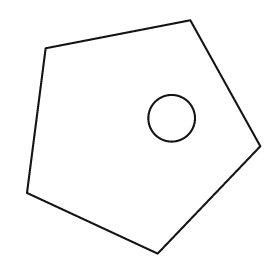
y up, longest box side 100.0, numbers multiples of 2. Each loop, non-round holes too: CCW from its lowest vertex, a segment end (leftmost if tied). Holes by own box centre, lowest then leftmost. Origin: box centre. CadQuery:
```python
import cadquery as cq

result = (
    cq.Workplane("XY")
    .moveTo(6.0, -50.0)
    .lineTo(50.0, -4.0)
    .lineTo(20.0, 50.0)
    .lineTo(-42.0, 38.0)
    .lineTo(-50.0, -24.0)
    .close()
    .moveTo(12.0, 8.0)
    .circle(10.0)
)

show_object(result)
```